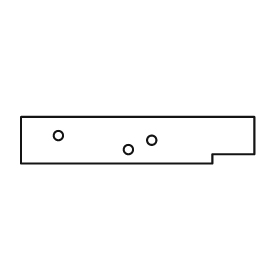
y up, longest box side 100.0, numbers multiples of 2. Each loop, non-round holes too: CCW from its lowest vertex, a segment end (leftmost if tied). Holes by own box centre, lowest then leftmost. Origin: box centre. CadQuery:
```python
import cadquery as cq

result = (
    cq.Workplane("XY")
    .moveTo(-50.0, -10.0)
    .lineTo(32.0, -10.0)
    .lineTo(32.0, -6.0)
    .lineTo(50.0, -6.0)
    .lineTo(50.0, 10.0)
    .lineTo(-50.0, 10.0)
    .close()
    .moveTo(-4.0, -4.0)
    .circle(2.0)
    .moveTo(6.0, 0.0)
    .circle(2.0)
    .moveTo(-34.0, 2.0)
    .circle(2.0)
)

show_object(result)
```